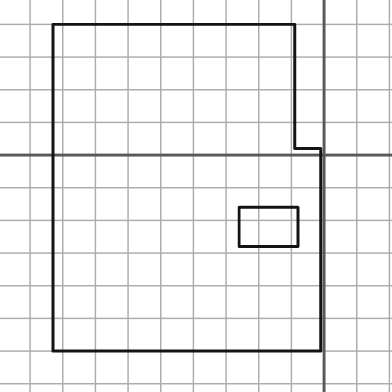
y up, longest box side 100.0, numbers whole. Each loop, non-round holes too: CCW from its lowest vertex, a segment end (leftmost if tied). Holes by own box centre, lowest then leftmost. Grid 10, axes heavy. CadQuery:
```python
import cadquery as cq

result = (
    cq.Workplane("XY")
    .moveTo(-83.0, -60.0)
    .lineTo(-1.0, -60.0)
    .lineTo(-1.0, 2.0)
    .lineTo(-9.0, 2.0)
    .lineTo(-9.0, 40.0)
    .lineTo(-83.0, 40.0)
    .close()
    .moveTo(-26.0, -28.0)
    .lineTo(-8.0, -28.0)
    .lineTo(-8.0, -16.0)
    .lineTo(-26.0, -16.0)
    .close()
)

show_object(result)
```